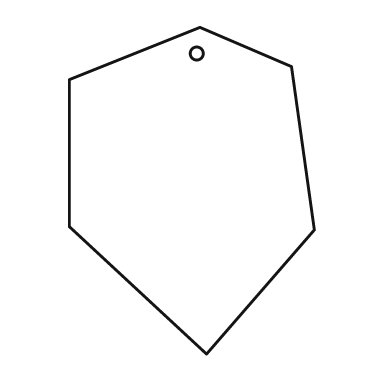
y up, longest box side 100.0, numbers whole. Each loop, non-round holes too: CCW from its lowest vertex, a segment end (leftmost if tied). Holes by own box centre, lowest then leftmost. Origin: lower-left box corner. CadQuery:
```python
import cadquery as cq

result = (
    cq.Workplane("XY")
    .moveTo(42.0, 0.0)
    .lineTo(75.0, 38.0)
    .lineTo(68.0, 88.0)
    .lineTo(40.0, 100.0)
    .lineTo(0.0, 84.0)
    .lineTo(0.0, 39.0)
    .close()
    .moveTo(39.0, 92.0)
    .circle(2.0)
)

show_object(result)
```